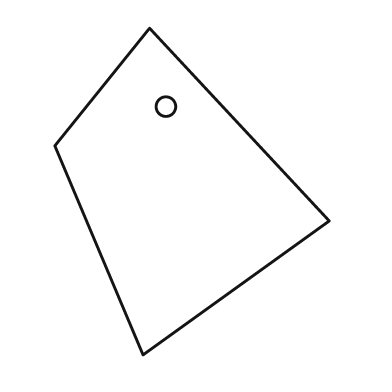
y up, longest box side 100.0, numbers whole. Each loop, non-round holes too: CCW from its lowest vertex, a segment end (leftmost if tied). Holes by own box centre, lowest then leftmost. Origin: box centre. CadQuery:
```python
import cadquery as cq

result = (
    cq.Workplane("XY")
    .moveTo(-15.0, -50.0)
    .lineTo(42.0, -9.0)
    .lineTo(-13.0, 50.0)
    .lineTo(-42.0, 14.0)
    .close()
    .moveTo(-8.0, 26.0)
    .circle(3.0)
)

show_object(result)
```